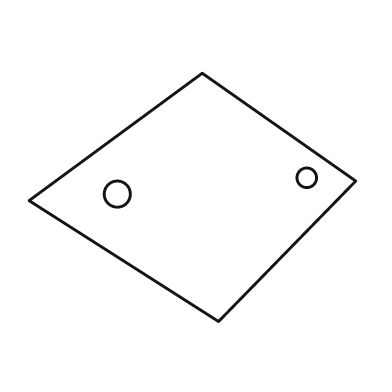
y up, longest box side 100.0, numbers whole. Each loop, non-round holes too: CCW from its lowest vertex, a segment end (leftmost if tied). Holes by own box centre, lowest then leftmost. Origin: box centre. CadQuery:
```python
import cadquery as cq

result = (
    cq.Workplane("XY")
    .moveTo(8.0, -38.0)
    .lineTo(50.0, 5.0)
    .lineTo(3.0, 38.0)
    .lineTo(-50.0, -1.0)
    .close()
    .moveTo(-23.0, 1.0)
    .circle(4.0)
    .moveTo(35.0, 6.0)
    .circle(3.0)
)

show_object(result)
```